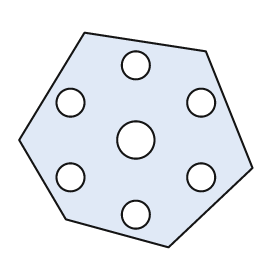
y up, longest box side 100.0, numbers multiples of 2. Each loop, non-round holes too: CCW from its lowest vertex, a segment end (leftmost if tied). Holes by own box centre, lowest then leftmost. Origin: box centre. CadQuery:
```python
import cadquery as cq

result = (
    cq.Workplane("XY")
    .moveTo(14.0, -46.0)
    .lineTo(50.0, -12.0)
    .lineTo(30.0, 38.0)
    .lineTo(-22.0, 46.0)
    .lineTo(-50.0, 0.0)
    .lineTo(-30.0, -34.0)
    .close()
    .moveTo(0.0, -32.0)
    .circle(6.0)
    .moveTo(-28.0, -16.0)
    .circle(6.0)
    .moveTo(28.0, -16.0)
    .circle(6.0)
    .moveTo(0.0, 0.0)
    .circle(8.0)
    .moveTo(-28.0, 16.0)
    .circle(6.0)
    .moveTo(28.0, 16.0)
    .circle(6.0)
    .moveTo(0.0, 32.0)
    .circle(6.0)
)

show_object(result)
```